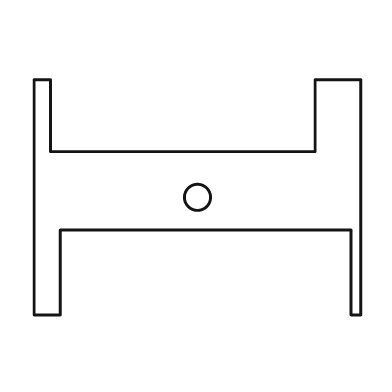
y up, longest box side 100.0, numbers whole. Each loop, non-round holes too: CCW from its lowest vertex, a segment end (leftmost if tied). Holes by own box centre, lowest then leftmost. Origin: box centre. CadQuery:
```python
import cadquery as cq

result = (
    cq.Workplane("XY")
    .moveTo(-50.0, -36.0)
    .lineTo(-42.0, -36.0)
    .lineTo(-42.0, -10.0)
    .lineTo(47.0, -10.0)
    .lineTo(47.0, -36.0)
    .lineTo(50.0, -36.0)
    .lineTo(50.0, 36.0)
    .lineTo(36.0, 36.0)
    .lineTo(36.0, 14.0)
    .lineTo(-45.0, 14.0)
    .lineTo(-45.0, 36.0)
    .lineTo(-50.0, 36.0)
    .close()
    .moveTo(0.0, 0.0)
    .circle(4.0)
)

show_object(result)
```